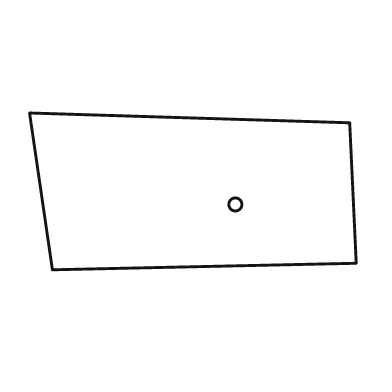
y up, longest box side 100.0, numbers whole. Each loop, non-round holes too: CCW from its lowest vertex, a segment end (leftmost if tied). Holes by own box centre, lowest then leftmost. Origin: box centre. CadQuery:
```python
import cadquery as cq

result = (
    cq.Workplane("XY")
    .moveTo(-43.0, -24.0)
    .lineTo(50.0, -22.0)
    .lineTo(48.0, 21.0)
    .lineTo(-50.0, 24.0)
    .close()
    .moveTo(13.0, -4.0)
    .circle(2.0)
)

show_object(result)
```